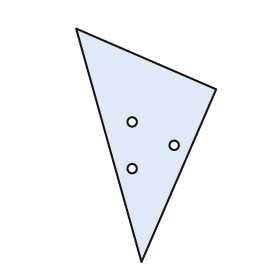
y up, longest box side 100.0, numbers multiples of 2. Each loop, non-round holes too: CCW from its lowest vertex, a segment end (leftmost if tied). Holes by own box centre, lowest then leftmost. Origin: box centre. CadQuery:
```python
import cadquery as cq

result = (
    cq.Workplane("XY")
    .moveTo(-2.0, -50.0)
    .lineTo(30.0, 24.0)
    .lineTo(-30.0, 50.0)
    .close()
    .moveTo(-6.0, -10.0)
    .circle(2.0)
    .moveTo(12.0, 0.0)
    .circle(2.0)
    .moveTo(-6.0, 10.0)
    .circle(2.0)
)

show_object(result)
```